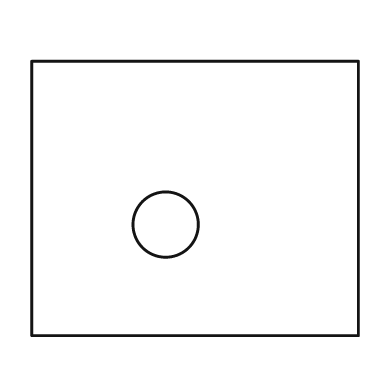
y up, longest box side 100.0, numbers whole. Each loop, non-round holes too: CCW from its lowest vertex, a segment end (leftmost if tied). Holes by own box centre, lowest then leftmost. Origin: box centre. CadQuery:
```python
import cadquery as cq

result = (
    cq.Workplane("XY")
    .moveTo(-50.0, -42.0)
    .lineTo(50.0, -42.0)
    .lineTo(50.0, 42.0)
    .lineTo(-50.0, 42.0)
    .close()
    .moveTo(-9.0, -8.0)
    .circle(10.0)
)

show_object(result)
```